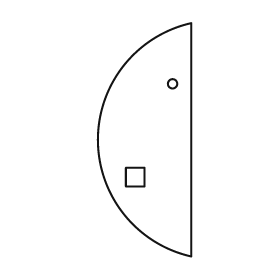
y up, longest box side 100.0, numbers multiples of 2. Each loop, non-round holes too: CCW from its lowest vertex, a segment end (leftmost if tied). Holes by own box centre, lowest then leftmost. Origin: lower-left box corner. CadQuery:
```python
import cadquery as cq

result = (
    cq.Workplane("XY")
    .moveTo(40.0, 0.0)
    .lineTo(40.0, 100.0)
    .threePointArc((0.0, 50.0), (40.0, 0.0))
    .close()
    .moveTo(12.0, 30.0)
    .lineTo(20.0, 30.0)
    .lineTo(20.0, 38.0)
    .lineTo(12.0, 38.0)
    .close()
    .moveTo(32.0, 74.0)
    .circle(2.0)
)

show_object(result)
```